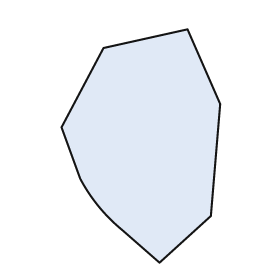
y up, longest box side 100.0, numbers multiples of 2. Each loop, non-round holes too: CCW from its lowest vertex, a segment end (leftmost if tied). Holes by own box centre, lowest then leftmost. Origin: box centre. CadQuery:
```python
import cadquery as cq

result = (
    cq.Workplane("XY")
    .moveTo(8.0, -50.0)
    .lineTo(30.0, -30.0)
    .lineTo(34.0, 18.0)
    .lineTo(20.0, 50.0)
    .lineTo(-16.0, 42.0)
    .lineTo(-34.0, 8.0)
    .lineTo(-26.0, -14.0)
    .threePointArc((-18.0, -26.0), (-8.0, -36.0))
    .close()
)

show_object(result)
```